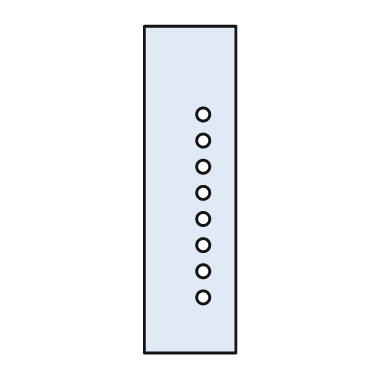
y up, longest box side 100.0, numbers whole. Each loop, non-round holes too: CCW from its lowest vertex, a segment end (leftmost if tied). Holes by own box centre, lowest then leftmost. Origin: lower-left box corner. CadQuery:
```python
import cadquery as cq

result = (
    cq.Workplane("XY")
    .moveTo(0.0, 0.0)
    .lineTo(28.0, 0.0)
    .lineTo(28.0, 100.0)
    .lineTo(0.0, 100.0)
    .close()
    .moveTo(18.0, 17.0)
    .circle(2.0)
    .moveTo(18.0, 25.0)
    .circle(2.0)
    .moveTo(18.0, 33.0)
    .circle(2.0)
    .moveTo(18.0, 41.0)
    .circle(2.0)
    .moveTo(18.0, 49.0)
    .circle(2.0)
    .moveTo(18.0, 57.0)
    .circle(2.0)
    .moveTo(18.0, 65.0)
    .circle(2.0)
    .moveTo(18.0, 73.0)
    .circle(2.0)
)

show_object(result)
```